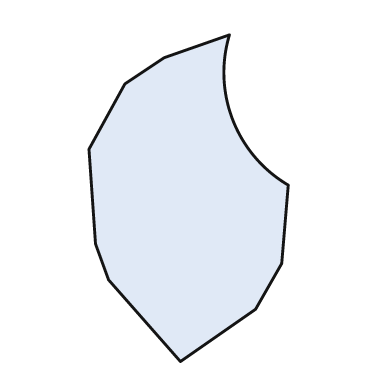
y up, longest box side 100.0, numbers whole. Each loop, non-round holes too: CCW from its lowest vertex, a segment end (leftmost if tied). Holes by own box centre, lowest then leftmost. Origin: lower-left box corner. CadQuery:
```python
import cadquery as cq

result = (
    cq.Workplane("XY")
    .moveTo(28.0, 0.0)
    .lineTo(51.0, 16.0)
    .lineTo(59.0, 30.0)
    .lineTo(61.0, 54.0)
    .threePointArc((44.0, 74.0), (43.0, 100.0))
    .lineTo(23.0, 93.0)
    .lineTo(11.0, 85.0)
    .lineTo(0.0, 65.0)
    .lineTo(2.0, 36.0)
    .lineTo(6.0, 25.0)
    .close()
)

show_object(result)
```